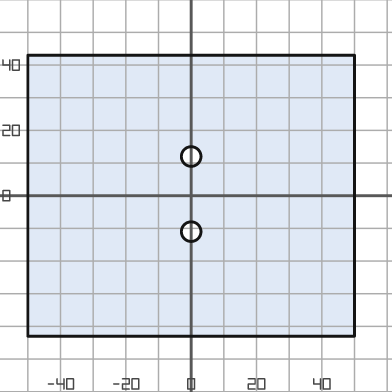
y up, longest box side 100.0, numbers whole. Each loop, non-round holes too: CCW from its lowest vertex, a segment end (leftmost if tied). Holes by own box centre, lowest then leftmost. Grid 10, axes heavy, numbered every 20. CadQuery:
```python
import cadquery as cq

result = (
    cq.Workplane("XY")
    .moveTo(-50.0, -43.0)
    .lineTo(50.0, -43.0)
    .lineTo(50.0, 43.0)
    .lineTo(-50.0, 43.0)
    .close()
    .moveTo(0.0, -11.0)
    .circle(3.0)
    .moveTo(0.0, 12.0)
    .circle(3.0)
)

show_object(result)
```